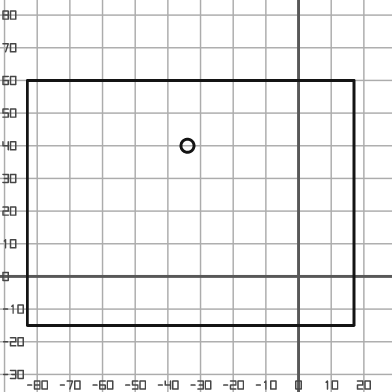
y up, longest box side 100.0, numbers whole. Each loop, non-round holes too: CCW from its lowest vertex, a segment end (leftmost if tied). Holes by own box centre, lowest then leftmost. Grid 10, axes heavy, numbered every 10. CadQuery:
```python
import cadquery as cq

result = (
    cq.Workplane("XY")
    .moveTo(-83.0, -15.0)
    .lineTo(17.0, -15.0)
    .lineTo(17.0, 60.0)
    .lineTo(-83.0, 60.0)
    .close()
    .moveTo(-34.0, 40.0)
    .circle(2.0)
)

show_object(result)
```